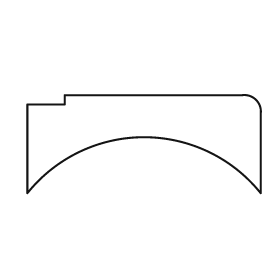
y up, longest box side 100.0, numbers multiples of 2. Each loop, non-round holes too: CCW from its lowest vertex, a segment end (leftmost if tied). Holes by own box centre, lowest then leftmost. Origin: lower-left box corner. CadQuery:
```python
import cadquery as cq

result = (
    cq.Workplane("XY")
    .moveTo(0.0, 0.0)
    .threePointArc((50.0, 24.0), (100.0, 0.0))
    .lineTo(100.0, 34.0)
    .threePointArc((98.0, 40.0), (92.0, 42.0))
    .lineTo(16.0, 42.0)
    .lineTo(16.0, 38.0)
    .lineTo(0.0, 38.0)
    .close()
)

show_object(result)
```